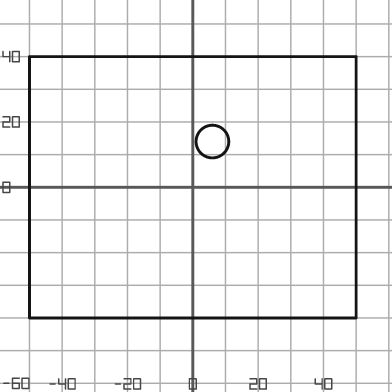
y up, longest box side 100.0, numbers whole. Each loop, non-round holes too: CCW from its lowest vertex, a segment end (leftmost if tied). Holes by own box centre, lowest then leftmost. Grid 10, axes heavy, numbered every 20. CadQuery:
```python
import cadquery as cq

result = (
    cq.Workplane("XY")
    .moveTo(-50.0, -40.0)
    .lineTo(50.0, -40.0)
    .lineTo(50.0, 40.0)
    .lineTo(-50.0, 40.0)
    .close()
    .moveTo(6.0, 14.0)
    .circle(5.0)
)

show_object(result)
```